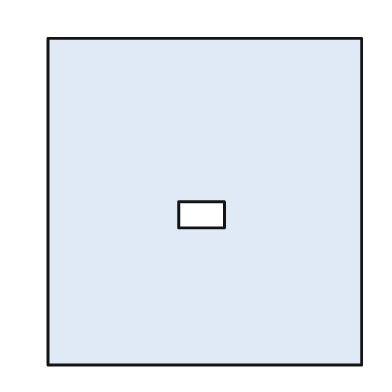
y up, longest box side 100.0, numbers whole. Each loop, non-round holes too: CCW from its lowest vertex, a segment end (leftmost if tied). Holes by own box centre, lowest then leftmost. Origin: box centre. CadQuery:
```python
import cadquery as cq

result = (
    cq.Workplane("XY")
    .moveTo(-48.0, -50.0)
    .lineTo(48.0, -50.0)
    .lineTo(48.0, 50.0)
    .lineTo(-48.0, 50.0)
    .close()
    .moveTo(-8.0, -8.0)
    .lineTo(6.0, -8.0)
    .lineTo(6.0, 0.0)
    .lineTo(-8.0, 0.0)
    .close()
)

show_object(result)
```